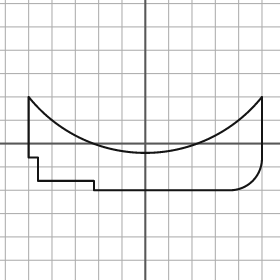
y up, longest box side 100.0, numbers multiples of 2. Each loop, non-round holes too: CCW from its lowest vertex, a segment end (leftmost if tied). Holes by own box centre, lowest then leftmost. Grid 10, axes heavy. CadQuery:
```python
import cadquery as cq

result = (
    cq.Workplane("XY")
    .moveTo(-22.0, -20.0)
    .lineTo(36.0, -20.0)
    .threePointArc((46.0, -16.0), (50.0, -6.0))
    .lineTo(50.0, 20.0)
    .threePointArc((0.0, -4.0), (-50.0, 20.0))
    .lineTo(-50.0, -6.0)
    .lineTo(-46.0, -6.0)
    .lineTo(-46.0, -16.0)
    .lineTo(-22.0, -16.0)
    .close()
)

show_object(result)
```